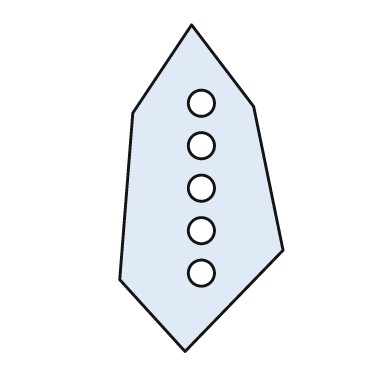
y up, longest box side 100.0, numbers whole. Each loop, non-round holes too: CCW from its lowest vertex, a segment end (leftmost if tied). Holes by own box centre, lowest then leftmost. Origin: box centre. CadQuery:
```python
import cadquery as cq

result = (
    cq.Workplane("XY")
    .moveTo(-5.0, -50.0)
    .lineTo(25.0, -19.0)
    .lineTo(16.0, 25.0)
    .lineTo(-3.0, 50.0)
    .lineTo(-21.0, 23.0)
    .lineTo(-25.0, -28.0)
    .close()
    .moveTo(0.0, -26.0)
    .circle(4.0)
    .moveTo(0.0, -13.0)
    .circle(4.0)
    .moveTo(0.0, 0.0)
    .circle(4.0)
    .moveTo(0.0, 13.0)
    .circle(4.0)
    .moveTo(0.0, 26.0)
    .circle(4.0)
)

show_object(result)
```